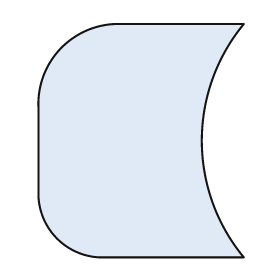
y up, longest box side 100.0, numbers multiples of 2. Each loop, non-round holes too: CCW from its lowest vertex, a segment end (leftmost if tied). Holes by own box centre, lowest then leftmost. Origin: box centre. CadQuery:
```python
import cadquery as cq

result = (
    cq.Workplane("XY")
    .moveTo(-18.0, -50.0)
    .lineTo(44.0, -50.0)
    .threePointArc((26.0, 0.0), (44.0, 50.0))
    .lineTo(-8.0, 50.0)
    .threePointArc((-34.0, 40.0), (-44.0, 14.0))
    .lineTo(-44.0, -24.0)
    .threePointArc((-36.0, -42.0), (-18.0, -50.0))
    .close()
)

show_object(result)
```